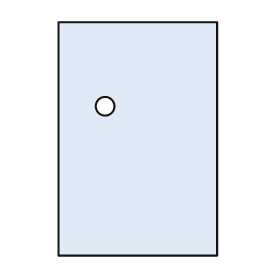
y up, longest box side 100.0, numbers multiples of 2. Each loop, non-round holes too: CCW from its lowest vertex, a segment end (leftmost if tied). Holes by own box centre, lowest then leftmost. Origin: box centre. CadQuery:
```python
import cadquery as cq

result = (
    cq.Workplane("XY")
    .moveTo(-34.0, -50.0)
    .lineTo(34.0, -50.0)
    .lineTo(34.0, 50.0)
    .lineTo(-34.0, 50.0)
    .close()
    .moveTo(-14.0, 14.0)
    .circle(4.0)
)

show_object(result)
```